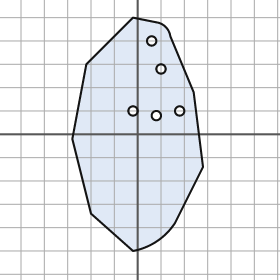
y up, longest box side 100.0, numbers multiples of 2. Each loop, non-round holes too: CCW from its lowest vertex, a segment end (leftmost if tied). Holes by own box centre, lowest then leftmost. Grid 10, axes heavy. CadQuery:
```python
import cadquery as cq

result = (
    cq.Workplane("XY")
    .moveTo(-2.0, -50.0)
    .threePointArc((8.0, -46.0), (16.0, -38.0))
    .lineTo(28.0, -14.0)
    .lineTo(24.0, 18.0)
    .lineTo(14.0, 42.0)
    .threePointArc((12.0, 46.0), (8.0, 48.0))
    .lineTo(-2.0, 50.0)
    .lineTo(-22.0, 30.0)
    .lineTo(-28.0, -2.0)
    .lineTo(-20.0, -34.0)
    .close()
    .moveTo(8.0, 8.0)
    .circle(2.0)
    .moveTo(-2.0, 10.0)
    .circle(2.0)
    .moveTo(18.0, 10.0)
    .circle(2.0)
    .moveTo(10.0, 28.0)
    .circle(2.0)
    .moveTo(6.0, 40.0)
    .circle(2.0)
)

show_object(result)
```